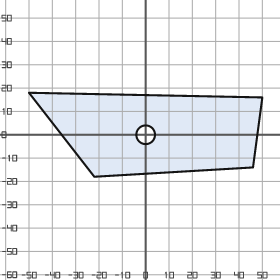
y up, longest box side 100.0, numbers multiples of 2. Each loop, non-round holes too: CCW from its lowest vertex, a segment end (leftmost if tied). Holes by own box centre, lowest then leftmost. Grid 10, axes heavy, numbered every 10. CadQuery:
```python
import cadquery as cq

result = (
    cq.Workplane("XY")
    .moveTo(-22.0, -18.0)
    .lineTo(46.0, -14.0)
    .lineTo(50.0, 16.0)
    .lineTo(-50.0, 18.0)
    .close()
    .moveTo(0.0, 0.0)
    .circle(4.0)
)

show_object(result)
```